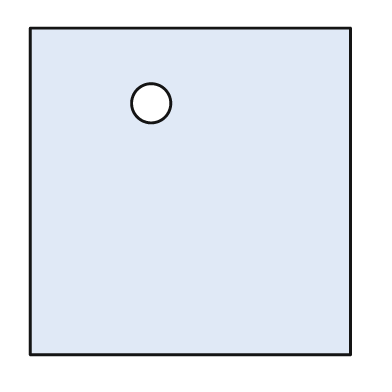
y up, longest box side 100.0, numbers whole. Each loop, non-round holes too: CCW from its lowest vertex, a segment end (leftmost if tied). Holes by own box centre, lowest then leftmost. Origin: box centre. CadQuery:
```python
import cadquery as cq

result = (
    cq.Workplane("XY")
    .moveTo(-49.0, -50.0)
    .lineTo(49.0, -50.0)
    .lineTo(49.0, 50.0)
    .lineTo(-49.0, 50.0)
    .close()
    .moveTo(-12.0, 27.0)
    .circle(6.0)
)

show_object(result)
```